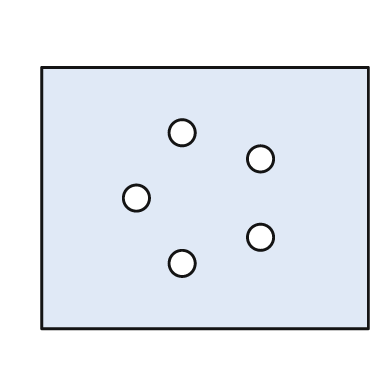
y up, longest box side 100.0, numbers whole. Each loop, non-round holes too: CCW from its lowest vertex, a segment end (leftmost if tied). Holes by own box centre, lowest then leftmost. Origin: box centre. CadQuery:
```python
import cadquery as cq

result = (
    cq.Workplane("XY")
    .moveTo(-50.0, -40.0)
    .lineTo(50.0, -40.0)
    .lineTo(50.0, 40.0)
    .lineTo(-50.0, 40.0)
    .close()
    .moveTo(-7.0, -20.0)
    .circle(4.0)
    .moveTo(17.0, -12.0)
    .circle(4.0)
    .moveTo(-21.0, 0.0)
    .circle(4.0)
    .moveTo(17.0, 12.0)
    .circle(4.0)
    .moveTo(-7.0, 20.0)
    .circle(4.0)
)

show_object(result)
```